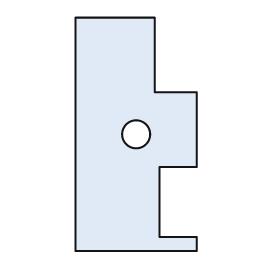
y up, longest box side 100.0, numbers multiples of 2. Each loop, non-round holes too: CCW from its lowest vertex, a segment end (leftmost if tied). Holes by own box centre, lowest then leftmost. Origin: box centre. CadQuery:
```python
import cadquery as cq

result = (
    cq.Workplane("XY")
    .moveTo(-26.0, -50.0)
    .lineTo(26.0, -50.0)
    .lineTo(26.0, -44.0)
    .lineTo(10.0, -44.0)
    .lineTo(10.0, -14.0)
    .lineTo(26.0, -14.0)
    .lineTo(26.0, 18.0)
    .lineTo(8.0, 18.0)
    .lineTo(8.0, 50.0)
    .lineTo(-26.0, 50.0)
    .close()
    .moveTo(0.0, 0.0)
    .circle(6.0)
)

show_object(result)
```